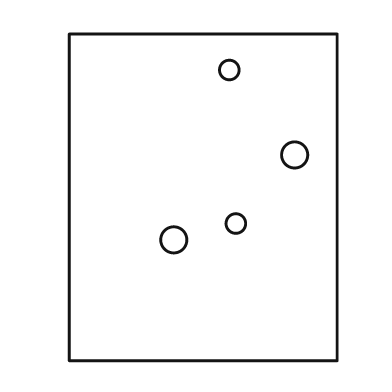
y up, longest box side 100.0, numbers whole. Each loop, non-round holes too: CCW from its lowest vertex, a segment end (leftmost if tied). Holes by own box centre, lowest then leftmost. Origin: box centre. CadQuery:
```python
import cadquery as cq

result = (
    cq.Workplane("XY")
    .moveTo(-41.0, -50.0)
    .lineTo(41.0, -50.0)
    .lineTo(41.0, 50.0)
    .lineTo(-41.0, 50.0)
    .close()
    .moveTo(-9.0, -13.0)
    .circle(4.0)
    .moveTo(10.0, -8.0)
    .circle(3.0)
    .moveTo(28.0, 13.0)
    .circle(4.0)
    .moveTo(8.0, 39.0)
    .circle(3.0)
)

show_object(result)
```